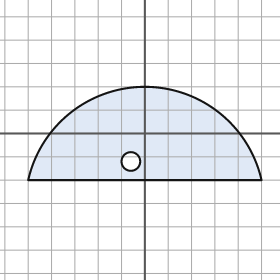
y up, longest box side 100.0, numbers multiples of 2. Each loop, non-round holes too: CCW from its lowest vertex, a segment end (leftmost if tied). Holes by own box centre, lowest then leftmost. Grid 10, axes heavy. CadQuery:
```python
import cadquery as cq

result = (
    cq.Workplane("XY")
    .moveTo(-50.0, -20.0)
    .lineTo(50.0, -20.0)
    .threePointArc((0.0, 20.0), (-50.0, -20.0))
    .close()
    .moveTo(-6.0, -12.0)
    .circle(4.0)
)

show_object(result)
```